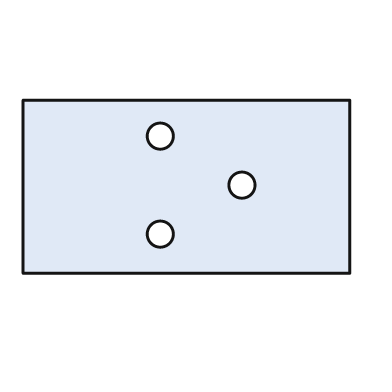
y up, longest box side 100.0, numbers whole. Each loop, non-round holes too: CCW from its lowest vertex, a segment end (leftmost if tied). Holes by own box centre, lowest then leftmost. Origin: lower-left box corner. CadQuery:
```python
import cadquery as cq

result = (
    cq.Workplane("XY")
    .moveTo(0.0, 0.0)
    .lineTo(100.0, 0.0)
    .lineTo(100.0, 53.0)
    .lineTo(0.0, 53.0)
    .close()
    .moveTo(42.0, 12.0)
    .circle(4.0)
    .moveTo(67.0, 27.0)
    .circle(4.0)
    .moveTo(42.0, 42.0)
    .circle(4.0)
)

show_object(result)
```